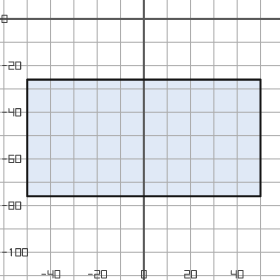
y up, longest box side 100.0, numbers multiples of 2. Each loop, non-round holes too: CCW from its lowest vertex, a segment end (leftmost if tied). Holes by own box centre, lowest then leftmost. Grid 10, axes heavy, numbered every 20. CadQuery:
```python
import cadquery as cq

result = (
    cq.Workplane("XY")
    .moveTo(-50.0, -76.0)
    .lineTo(50.0, -76.0)
    .lineTo(50.0, -26.0)
    .lineTo(-50.0, -26.0)
    .close()
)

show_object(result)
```